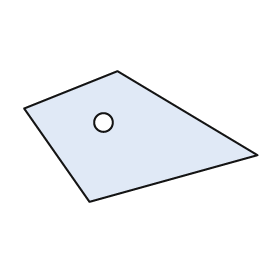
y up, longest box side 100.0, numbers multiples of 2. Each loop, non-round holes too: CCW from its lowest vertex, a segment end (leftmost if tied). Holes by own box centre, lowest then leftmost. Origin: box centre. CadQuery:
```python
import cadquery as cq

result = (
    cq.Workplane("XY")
    .moveTo(-22.0, -28.0)
    .lineTo(50.0, -8.0)
    .lineTo(-10.0, 28.0)
    .lineTo(-50.0, 12.0)
    .close()
    .moveTo(-16.0, 6.0)
    .circle(4.0)
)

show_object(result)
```